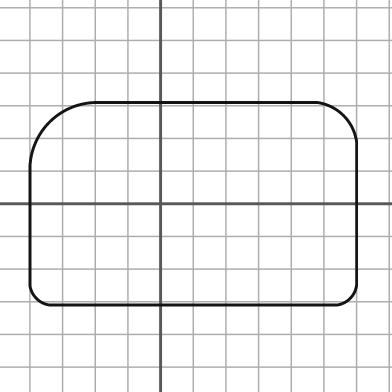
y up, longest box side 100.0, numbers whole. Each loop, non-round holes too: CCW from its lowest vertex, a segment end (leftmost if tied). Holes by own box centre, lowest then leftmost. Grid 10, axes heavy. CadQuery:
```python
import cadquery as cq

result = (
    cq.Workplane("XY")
    .moveTo(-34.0, -31.0)
    .lineTo(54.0, -31.0)
    .threePointArc((58.0, -29.0), (60.0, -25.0))
    .lineTo(60.0, 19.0)
    .threePointArc((56.0, 27.0), (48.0, 31.0))
    .lineTo(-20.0, 31.0)
    .threePointArc((-34.0, 25.0), (-40.0, 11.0))
    .lineTo(-40.0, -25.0)
    .threePointArc((-38.0, -29.0), (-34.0, -31.0))
    .close()
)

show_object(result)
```